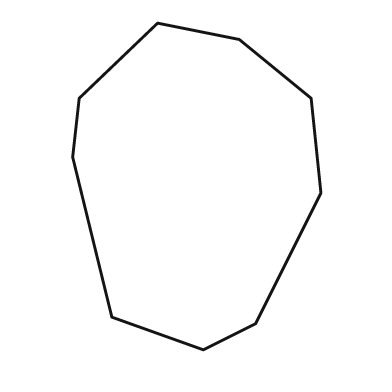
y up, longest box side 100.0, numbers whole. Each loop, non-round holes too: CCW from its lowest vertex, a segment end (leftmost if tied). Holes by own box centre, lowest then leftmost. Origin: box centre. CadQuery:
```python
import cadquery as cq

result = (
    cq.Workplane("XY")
    .moveTo(2.0, -50.0)
    .lineTo(18.0, -42.0)
    .lineTo(38.0, -2.0)
    .lineTo(35.0, 27.0)
    .lineTo(13.0, 45.0)
    .lineTo(-12.0, 50.0)
    .lineTo(-36.0, 27.0)
    .lineTo(-38.0, 9.0)
    .lineTo(-26.0, -40.0)
    .close()
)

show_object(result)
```